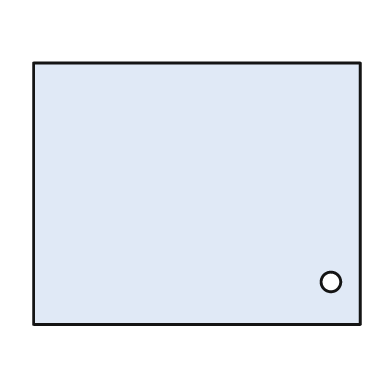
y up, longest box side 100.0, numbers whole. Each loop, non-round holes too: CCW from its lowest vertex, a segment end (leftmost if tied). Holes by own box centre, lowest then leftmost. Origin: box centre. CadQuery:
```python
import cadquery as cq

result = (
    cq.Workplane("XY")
    .moveTo(-50.0, -40.0)
    .lineTo(50.0, -40.0)
    .lineTo(50.0, 40.0)
    .lineTo(-50.0, 40.0)
    .close()
    .moveTo(41.0, -27.0)
    .circle(3.0)
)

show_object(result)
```